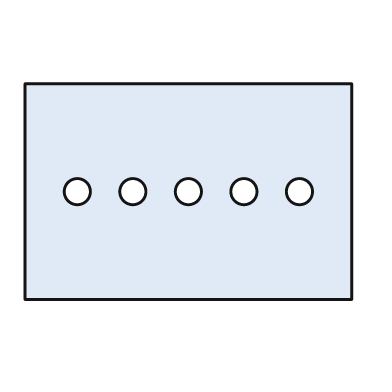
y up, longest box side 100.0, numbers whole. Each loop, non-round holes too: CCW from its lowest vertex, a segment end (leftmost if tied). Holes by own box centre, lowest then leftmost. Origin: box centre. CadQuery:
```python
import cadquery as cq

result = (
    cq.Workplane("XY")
    .moveTo(-50.0, -33.0)
    .lineTo(50.0, -33.0)
    .lineTo(50.0, 33.0)
    .lineTo(-50.0, 33.0)
    .close()
    .moveTo(-34.0, 0.0)
    .circle(4.0)
    .moveTo(-17.0, 0.0)
    .circle(4.0)
    .moveTo(0.0, 0.0)
    .circle(4.0)
    .moveTo(17.0, 0.0)
    .circle(4.0)
    .moveTo(34.0, 0.0)
    .circle(4.0)
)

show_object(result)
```